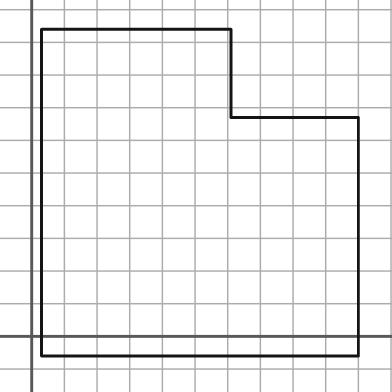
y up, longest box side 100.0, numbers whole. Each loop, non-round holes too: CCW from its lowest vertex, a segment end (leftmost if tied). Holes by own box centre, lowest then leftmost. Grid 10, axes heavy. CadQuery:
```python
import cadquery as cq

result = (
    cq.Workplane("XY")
    .moveTo(3.0, -6.0)
    .lineTo(100.0, -6.0)
    .lineTo(100.0, 67.0)
    .lineTo(61.0, 67.0)
    .lineTo(61.0, 94.0)
    .lineTo(3.0, 94.0)
    .close()
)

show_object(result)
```